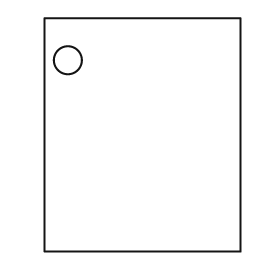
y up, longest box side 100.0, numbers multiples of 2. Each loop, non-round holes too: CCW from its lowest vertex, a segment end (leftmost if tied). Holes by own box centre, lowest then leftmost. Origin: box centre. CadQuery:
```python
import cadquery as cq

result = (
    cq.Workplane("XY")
    .moveTo(-42.0, -50.0)
    .lineTo(42.0, -50.0)
    .lineTo(42.0, 50.0)
    .lineTo(-42.0, 50.0)
    .close()
    .moveTo(-32.0, 32.0)
    .circle(6.0)
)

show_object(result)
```